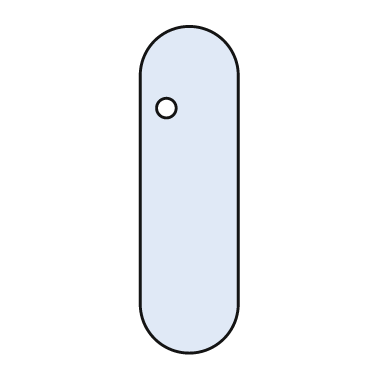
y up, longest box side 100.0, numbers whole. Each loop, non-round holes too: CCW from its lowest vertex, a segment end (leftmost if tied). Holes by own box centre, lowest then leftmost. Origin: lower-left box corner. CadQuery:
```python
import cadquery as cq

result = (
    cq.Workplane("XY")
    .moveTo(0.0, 15.0)
    .threePointArc((15.0, 0.0), (30.0, 15.0))
    .lineTo(30.0, 85.0)
    .threePointArc((15.0, 100.0), (0.0, 85.0))
    .close()
    .moveTo(8.0, 75.0)
    .circle(3.0)
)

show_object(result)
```